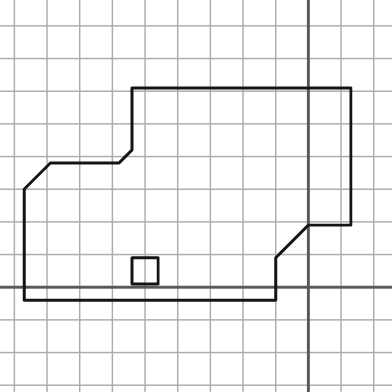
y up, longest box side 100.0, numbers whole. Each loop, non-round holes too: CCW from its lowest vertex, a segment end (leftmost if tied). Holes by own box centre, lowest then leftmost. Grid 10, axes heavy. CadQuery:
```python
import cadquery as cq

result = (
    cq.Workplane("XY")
    .moveTo(-87.0, -4.0)
    .lineTo(-10.0, -4.0)
    .lineTo(-10.0, 9.0)
    .lineTo(0.0, 19.0)
    .lineTo(13.0, 19.0)
    .lineTo(13.0, 61.0)
    .lineTo(-54.0, 61.0)
    .lineTo(-54.0, 42.0)
    .lineTo(-58.0, 38.0)
    .lineTo(-79.0, 38.0)
    .lineTo(-87.0, 30.0)
    .close()
    .moveTo(-54.0, 1.0)
    .lineTo(-46.0, 1.0)
    .lineTo(-46.0, 9.0)
    .lineTo(-54.0, 9.0)
    .close()
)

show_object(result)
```